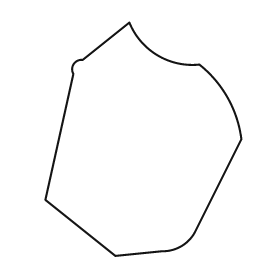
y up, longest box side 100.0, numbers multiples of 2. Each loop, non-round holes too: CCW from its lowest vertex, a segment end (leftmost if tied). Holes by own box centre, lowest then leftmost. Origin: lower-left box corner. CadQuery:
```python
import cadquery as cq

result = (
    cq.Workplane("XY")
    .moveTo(30.0, 0.0)
    .lineTo(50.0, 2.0)
    .threePointArc((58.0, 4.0), (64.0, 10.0))
    .lineTo(84.0, 50.0)
    .threePointArc((78.0, 68.0), (66.0, 82.0))
    .threePointArc((48.0, 86.0), (36.0, 100.0))
    .lineTo(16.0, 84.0)
    .threePointArc((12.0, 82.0), (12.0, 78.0))
    .lineTo(0.0, 24.0)
    .close()
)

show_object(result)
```